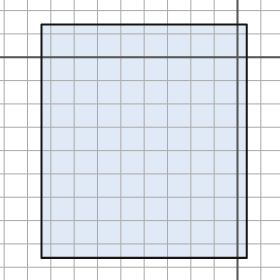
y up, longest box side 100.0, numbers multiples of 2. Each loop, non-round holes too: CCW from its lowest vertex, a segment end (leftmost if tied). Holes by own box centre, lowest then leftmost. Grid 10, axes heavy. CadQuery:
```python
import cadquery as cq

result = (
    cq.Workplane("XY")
    .moveTo(-84.0, -86.0)
    .lineTo(4.0, -86.0)
    .lineTo(4.0, 14.0)
    .lineTo(-84.0, 14.0)
    .close()
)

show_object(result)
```